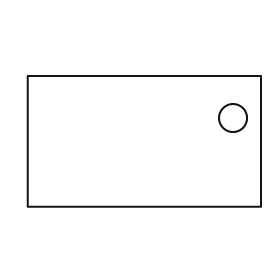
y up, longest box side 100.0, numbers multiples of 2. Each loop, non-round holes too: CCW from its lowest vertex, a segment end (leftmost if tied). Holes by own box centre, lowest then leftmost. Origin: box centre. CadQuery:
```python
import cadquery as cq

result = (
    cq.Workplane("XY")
    .moveTo(-50.0, -28.0)
    .lineTo(50.0, -28.0)
    .lineTo(50.0, 28.0)
    .lineTo(-50.0, 28.0)
    .close()
    .moveTo(38.0, 10.0)
    .circle(6.0)
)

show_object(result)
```